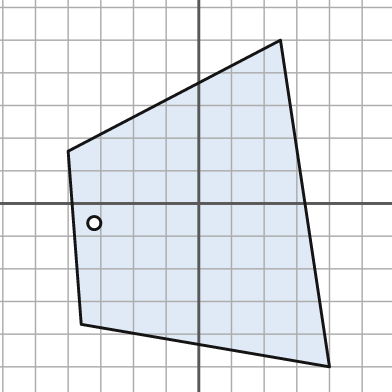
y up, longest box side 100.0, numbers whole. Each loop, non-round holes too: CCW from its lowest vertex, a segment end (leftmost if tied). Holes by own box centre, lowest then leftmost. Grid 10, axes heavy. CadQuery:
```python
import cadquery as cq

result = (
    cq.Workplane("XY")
    .moveTo(40.0, -50.0)
    .lineTo(25.0, 50.0)
    .lineTo(-40.0, 16.0)
    .lineTo(-36.0, -37.0)
    .close()
    .moveTo(-32.0, -6.0)
    .circle(2.0)
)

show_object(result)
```